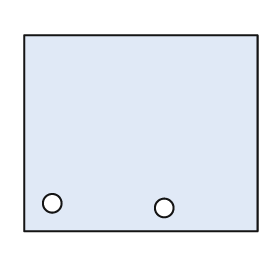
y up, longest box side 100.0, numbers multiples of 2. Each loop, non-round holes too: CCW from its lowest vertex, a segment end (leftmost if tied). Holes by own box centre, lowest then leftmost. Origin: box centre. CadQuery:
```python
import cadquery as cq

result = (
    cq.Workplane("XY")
    .moveTo(-50.0, -42.0)
    .lineTo(50.0, -42.0)
    .lineTo(50.0, 42.0)
    .lineTo(-50.0, 42.0)
    .close()
    .moveTo(10.0, -32.0)
    .circle(4.0)
    .moveTo(-38.0, -30.0)
    .circle(4.0)
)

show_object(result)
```